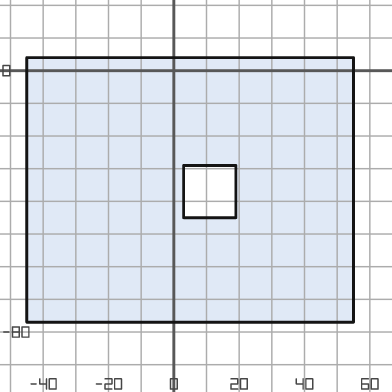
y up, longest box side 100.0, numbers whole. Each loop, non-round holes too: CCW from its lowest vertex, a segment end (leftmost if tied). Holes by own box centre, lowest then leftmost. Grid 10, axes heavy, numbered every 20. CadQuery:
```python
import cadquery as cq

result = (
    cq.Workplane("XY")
    .moveTo(-45.0, -77.0)
    .lineTo(55.0, -77.0)
    .lineTo(55.0, 4.0)
    .lineTo(-45.0, 4.0)
    .close()
    .moveTo(3.0, -45.0)
    .lineTo(19.0, -45.0)
    .lineTo(19.0, -29.0)
    .lineTo(3.0, -29.0)
    .close()
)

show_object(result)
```